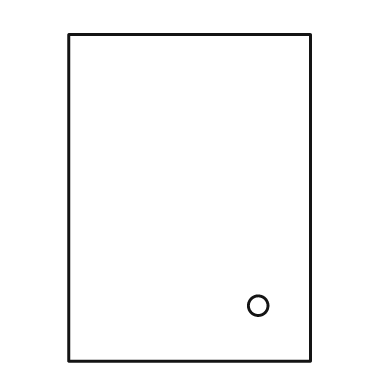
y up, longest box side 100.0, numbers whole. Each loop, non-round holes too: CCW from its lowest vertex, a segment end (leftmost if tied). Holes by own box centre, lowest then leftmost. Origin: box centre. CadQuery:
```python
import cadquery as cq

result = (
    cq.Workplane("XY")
    .moveTo(-37.0, -50.0)
    .lineTo(37.0, -50.0)
    .lineTo(37.0, 50.0)
    .lineTo(-37.0, 50.0)
    .close()
    .moveTo(21.0, -33.0)
    .circle(3.0)
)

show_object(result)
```